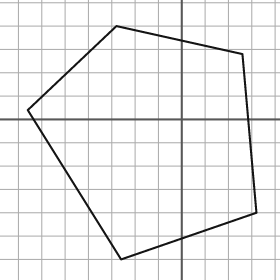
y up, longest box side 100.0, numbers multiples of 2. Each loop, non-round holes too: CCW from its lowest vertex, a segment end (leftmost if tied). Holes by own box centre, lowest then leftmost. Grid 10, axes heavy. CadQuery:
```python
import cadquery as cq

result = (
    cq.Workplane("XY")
    .moveTo(-26.0, -60.0)
    .lineTo(32.0, -40.0)
    .lineTo(26.0, 28.0)
    .lineTo(-28.0, 40.0)
    .lineTo(-66.0, 4.0)
    .close()
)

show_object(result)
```